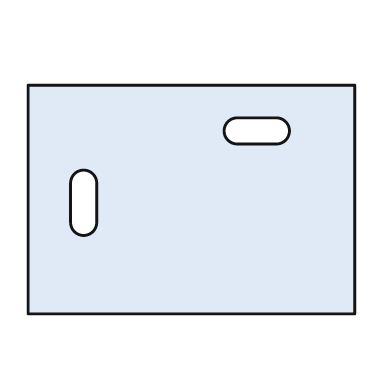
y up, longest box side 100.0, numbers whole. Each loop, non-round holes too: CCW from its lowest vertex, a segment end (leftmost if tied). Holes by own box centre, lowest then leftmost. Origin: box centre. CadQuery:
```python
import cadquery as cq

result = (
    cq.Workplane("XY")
    .moveTo(-50.0, -35.0)
    .lineTo(50.0, -35.0)
    .lineTo(50.0, 35.0)
    .lineTo(-50.0, 35.0)
    .close()
    .moveTo(-37.0, -7.0)
    .threePointArc((-33.0, -11.0), (-29.0, -7.0))
    .lineTo(-29.0, 5.0)
    .threePointArc((-33.0, 9.0), (-37.0, 5.0))
    .close()
    .moveTo(14.0, 17.0)
    .lineTo(26.0, 17.0)
    .threePointArc((30.0, 21.0), (26.0, 25.0))
    .lineTo(14.0, 25.0)
    .threePointArc((10.0, 21.0), (14.0, 17.0))
    .close()
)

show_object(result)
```